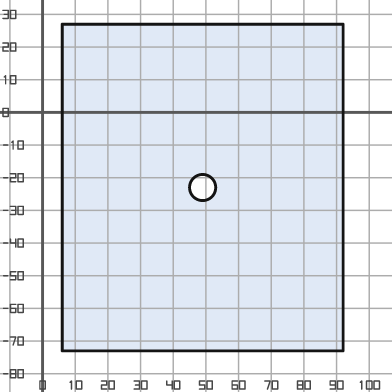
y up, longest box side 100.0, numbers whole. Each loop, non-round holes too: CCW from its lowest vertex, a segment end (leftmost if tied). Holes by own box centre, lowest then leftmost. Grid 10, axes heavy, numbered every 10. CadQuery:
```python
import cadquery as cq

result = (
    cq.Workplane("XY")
    .moveTo(6.0, -73.0)
    .lineTo(92.0, -73.0)
    .lineTo(92.0, 27.0)
    .lineTo(6.0, 27.0)
    .close()
    .moveTo(49.0, -23.0)
    .circle(4.0)
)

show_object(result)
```